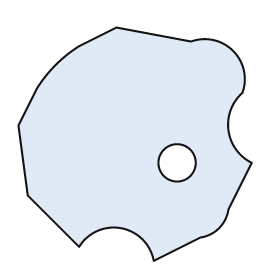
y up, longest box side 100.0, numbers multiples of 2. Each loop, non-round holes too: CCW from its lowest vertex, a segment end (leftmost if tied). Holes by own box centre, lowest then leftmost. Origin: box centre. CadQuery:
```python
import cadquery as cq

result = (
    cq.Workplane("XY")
    .moveTo(8.0, -50.0)
    .lineTo(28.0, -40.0)
    .threePointArc((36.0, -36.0), (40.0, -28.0))
    .lineTo(50.0, -8.0)
    .threePointArc((40.0, 6.0), (46.0, 22.0))
    .threePointArc((42.0, 40.0), (24.0, 44.0))
    .lineTo(-8.0, 50.0)
    .lineTo(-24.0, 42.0)
    .threePointArc((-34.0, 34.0), (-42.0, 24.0))
    .lineTo(-50.0, 8.0)
    .lineTo(-46.0, -22.0)
    .lineTo(-24.0, -44.0)
    .threePointArc((-6.0, -36.0), (8.0, -50.0))
    .close()
    .moveTo(18.0, -8.0)
    .circle(8.0)
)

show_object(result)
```